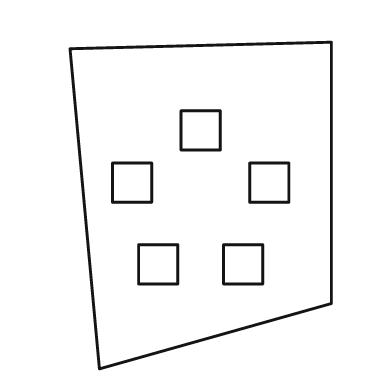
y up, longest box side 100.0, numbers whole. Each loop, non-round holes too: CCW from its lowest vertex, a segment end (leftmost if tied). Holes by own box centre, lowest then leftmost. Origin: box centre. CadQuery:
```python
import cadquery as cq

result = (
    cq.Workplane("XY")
    .moveTo(-31.0, -50.0)
    .lineTo(40.0, -30.0)
    .lineTo(40.0, 50.0)
    .lineTo(-40.0, 48.0)
    .close()
    .moveTo(-19.0, -24.0)
    .lineTo(-7.0, -24.0)
    .lineTo(-7.0, -12.0)
    .lineTo(-19.0, -12.0)
    .close()
    .moveTo(7.0, -24.0)
    .lineTo(19.0, -24.0)
    .lineTo(19.0, -12.0)
    .lineTo(7.0, -12.0)
    .close()
    .moveTo(-27.0, 1.0)
    .lineTo(-15.0, 1.0)
    .lineTo(-15.0, 13.0)
    .lineTo(-27.0, 13.0)
    .close()
    .moveTo(15.0, 1.0)
    .lineTo(27.0, 1.0)
    .lineTo(27.0, 13.0)
    .lineTo(15.0, 13.0)
    .close()
    .moveTo(-6.0, 17.0)
    .lineTo(6.0, 17.0)
    .lineTo(6.0, 29.0)
    .lineTo(-6.0, 29.0)
    .close()
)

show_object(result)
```